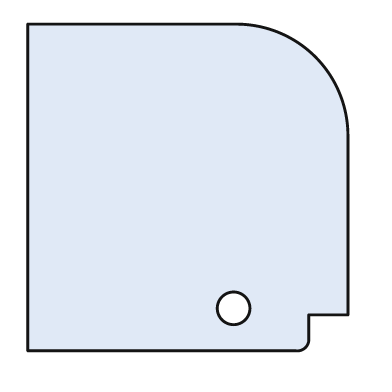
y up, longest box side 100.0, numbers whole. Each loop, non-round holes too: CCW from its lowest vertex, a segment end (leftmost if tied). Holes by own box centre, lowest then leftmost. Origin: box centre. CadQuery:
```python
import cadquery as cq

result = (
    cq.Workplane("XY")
    .moveTo(-49.0, -50.0)
    .lineTo(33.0, -50.0)
    .threePointArc((36.0, -49.0), (37.0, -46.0))
    .lineTo(37.0, -39.0)
    .lineTo(49.0, -39.0)
    .lineTo(49.0, 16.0)
    .threePointArc((39.0, 40.0), (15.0, 50.0))
    .lineTo(-49.0, 50.0)
    .close()
    .moveTo(14.0, -37.0)
    .circle(5.0)
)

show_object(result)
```